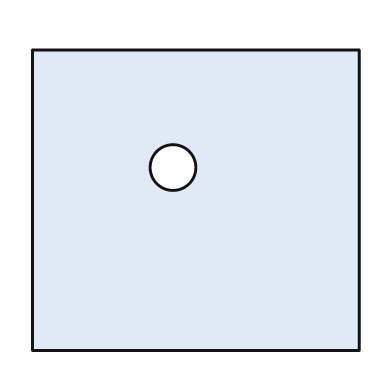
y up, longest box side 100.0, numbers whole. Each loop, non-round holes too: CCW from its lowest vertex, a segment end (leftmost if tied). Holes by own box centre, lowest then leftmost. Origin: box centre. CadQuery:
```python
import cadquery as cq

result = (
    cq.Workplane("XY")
    .moveTo(-50.0, -46.0)
    .lineTo(50.0, -46.0)
    .lineTo(50.0, 46.0)
    .lineTo(-50.0, 46.0)
    .close()
    .moveTo(-7.0, 10.0)
    .circle(7.0)
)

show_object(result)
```